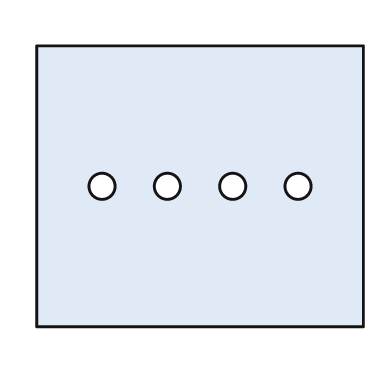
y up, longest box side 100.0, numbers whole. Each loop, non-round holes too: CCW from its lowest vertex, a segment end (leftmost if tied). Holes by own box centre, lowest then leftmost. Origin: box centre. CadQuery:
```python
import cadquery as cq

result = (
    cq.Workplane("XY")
    .moveTo(-50.0, -43.0)
    .lineTo(50.0, -43.0)
    .lineTo(50.0, 43.0)
    .lineTo(-50.0, 43.0)
    .close()
    .moveTo(-30.0, 0.0)
    .circle(4.0)
    .moveTo(-10.0, 0.0)
    .circle(4.0)
    .moveTo(10.0, 0.0)
    .circle(4.0)
    .moveTo(30.0, 0.0)
    .circle(4.0)
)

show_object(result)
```